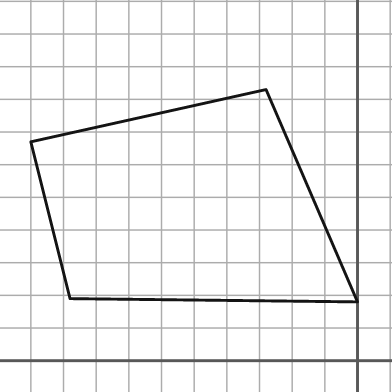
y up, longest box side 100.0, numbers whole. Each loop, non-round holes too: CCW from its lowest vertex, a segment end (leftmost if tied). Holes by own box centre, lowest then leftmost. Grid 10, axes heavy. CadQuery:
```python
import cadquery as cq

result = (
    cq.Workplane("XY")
    .moveTo(0.0, 18.0)
    .lineTo(-28.0, 83.0)
    .lineTo(-100.0, 67.0)
    .lineTo(-88.0, 19.0)
    .close()
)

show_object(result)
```